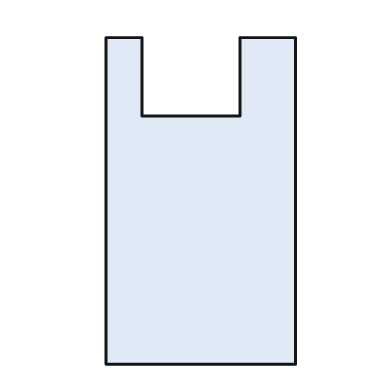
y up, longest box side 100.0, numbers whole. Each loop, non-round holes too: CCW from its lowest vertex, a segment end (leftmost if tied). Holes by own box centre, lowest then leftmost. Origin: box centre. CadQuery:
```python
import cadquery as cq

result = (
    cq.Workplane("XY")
    .moveTo(-29.0, -50.0)
    .lineTo(29.0, -50.0)
    .lineTo(29.0, 50.0)
    .lineTo(12.0, 50.0)
    .lineTo(12.0, 26.0)
    .lineTo(-18.0, 26.0)
    .lineTo(-18.0, 50.0)
    .lineTo(-29.0, 50.0)
    .close()
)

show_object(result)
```